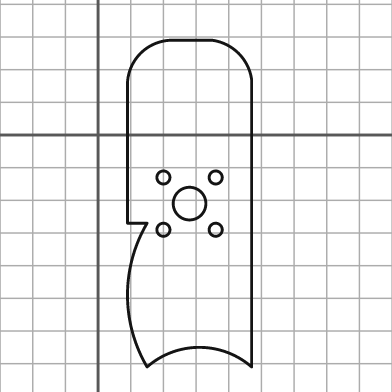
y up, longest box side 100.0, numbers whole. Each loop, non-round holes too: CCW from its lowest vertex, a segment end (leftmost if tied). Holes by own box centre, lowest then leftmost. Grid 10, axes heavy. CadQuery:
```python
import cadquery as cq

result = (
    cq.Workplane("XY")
    .moveTo(15.0, -71.0)
    .threePointArc((31.0, -65.0), (47.0, -71.0))
    .lineTo(47.0, 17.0)
    .threePointArc((43.0, 25.0), (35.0, 29.0))
    .lineTo(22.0, 29.0)
    .threePointArc((13.0, 25.0), (9.0, 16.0))
    .lineTo(9.0, -27.0)
    .lineTo(15.0, -27.0)
    .threePointArc((9.0, -49.0), (15.0, -71.0))
    .close()
    .moveTo(20.0, -29.0)
    .circle(2.0)
    .moveTo(36.0, -29.0)
    .circle(2.0)
    .moveTo(28.0, -21.0)
    .circle(5.0)
    .moveTo(20.0, -13.0)
    .circle(2.0)
    .moveTo(36.0, -13.0)
    .circle(2.0)
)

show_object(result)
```